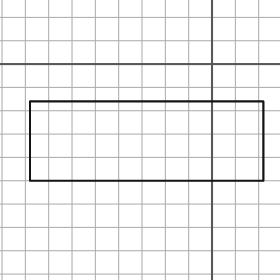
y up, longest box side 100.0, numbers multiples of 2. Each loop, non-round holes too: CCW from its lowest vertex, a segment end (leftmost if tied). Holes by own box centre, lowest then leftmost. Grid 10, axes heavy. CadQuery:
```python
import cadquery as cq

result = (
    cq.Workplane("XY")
    .moveTo(-78.0, -50.0)
    .lineTo(22.0, -50.0)
    .lineTo(22.0, -16.0)
    .lineTo(-78.0, -16.0)
    .close()
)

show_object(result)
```